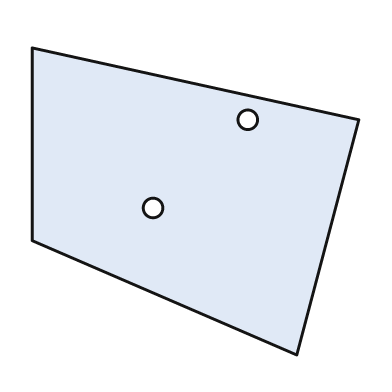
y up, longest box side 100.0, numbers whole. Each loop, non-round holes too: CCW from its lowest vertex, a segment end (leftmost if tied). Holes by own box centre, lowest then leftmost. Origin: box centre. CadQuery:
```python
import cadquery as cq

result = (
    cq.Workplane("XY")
    .moveTo(31.0, -47.0)
    .lineTo(50.0, 25.0)
    .lineTo(-50.0, 47.0)
    .lineTo(-50.0, -12.0)
    .close()
    .moveTo(-13.0, -2.0)
    .circle(3.0)
    .moveTo(16.0, 25.0)
    .circle(3.0)
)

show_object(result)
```